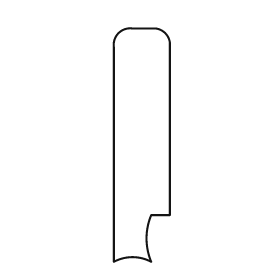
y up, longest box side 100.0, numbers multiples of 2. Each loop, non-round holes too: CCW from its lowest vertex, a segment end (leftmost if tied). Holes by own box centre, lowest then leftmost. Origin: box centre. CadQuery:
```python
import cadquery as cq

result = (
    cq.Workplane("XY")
    .moveTo(-12.0, -50.0)
    .threePointArc((-4.0, -48.0), (4.0, -50.0))
    .threePointArc((2.0, -40.0), (4.0, -30.0))
    .lineTo(12.0, -30.0)
    .lineTo(12.0, 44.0)
    .threePointArc((10.0, 48.0), (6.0, 50.0))
    .lineTo(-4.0, 50.0)
    .threePointArc((-10.0, 48.0), (-12.0, 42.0))
    .close()
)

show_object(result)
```